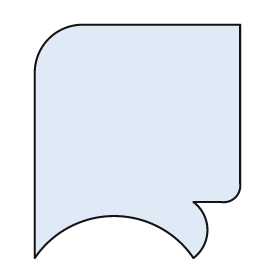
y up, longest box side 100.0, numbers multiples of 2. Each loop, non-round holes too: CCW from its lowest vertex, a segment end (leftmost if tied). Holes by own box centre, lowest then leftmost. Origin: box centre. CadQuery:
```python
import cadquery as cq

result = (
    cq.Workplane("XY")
    .moveTo(-44.0, -50.0)
    .threePointArc((-10.0, -32.0), (24.0, -50.0))
    .threePointArc((30.0, -38.0), (24.0, -26.0))
    .lineTo(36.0, -26.0)
    .threePointArc((42.0, -24.0), (44.0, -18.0))
    .lineTo(44.0, 50.0)
    .lineTo(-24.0, 50.0)
    .threePointArc((-38.0, 44.0), (-44.0, 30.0))
    .close()
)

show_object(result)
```